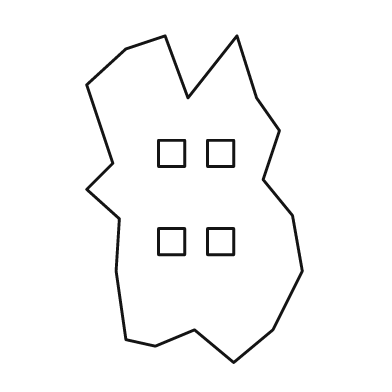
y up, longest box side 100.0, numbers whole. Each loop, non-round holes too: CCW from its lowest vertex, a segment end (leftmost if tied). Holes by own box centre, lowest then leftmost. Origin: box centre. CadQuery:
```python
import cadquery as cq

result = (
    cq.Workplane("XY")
    .moveTo(12.0, -50.0)
    .lineTo(24.0, -40.0)
    .lineTo(33.0, -22.0)
    .lineTo(30.0, -5.0)
    .lineTo(21.0, 6.0)
    .lineTo(26.0, 21.0)
    .lineTo(19.0, 31.0)
    .lineTo(13.0, 50.0)
    .lineTo(-2.0, 31.0)
    .lineTo(-9.0, 50.0)
    .lineTo(-21.0, 46.0)
    .lineTo(-33.0, 35.0)
    .lineTo(-25.0, 11.0)
    .lineTo(-33.0, 3.0)
    .lineTo(-23.0, -6.0)
    .lineTo(-24.0, -22.0)
    .lineTo(-21.0, -43.0)
    .lineTo(-12.0, -45.0)
    .lineTo(0.0, -40.0)
    .close()
    .moveTo(-11.0, -17.0)
    .lineTo(-3.0, -17.0)
    .lineTo(-3.0, -9.0)
    .lineTo(-11.0, -9.0)
    .close()
    .moveTo(4.0, -17.0)
    .lineTo(12.0, -17.0)
    .lineTo(12.0, -9.0)
    .lineTo(4.0, -9.0)
    .close()
    .moveTo(-11.0, 10.0)
    .lineTo(-3.0, 10.0)
    .lineTo(-3.0, 18.0)
    .lineTo(-11.0, 18.0)
    .close()
    .moveTo(4.0, 10.0)
    .lineTo(12.0, 10.0)
    .lineTo(12.0, 18.0)
    .lineTo(4.0, 18.0)
    .close()
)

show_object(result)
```